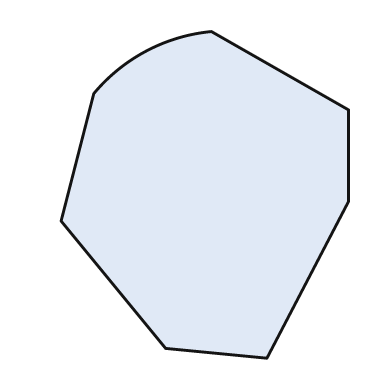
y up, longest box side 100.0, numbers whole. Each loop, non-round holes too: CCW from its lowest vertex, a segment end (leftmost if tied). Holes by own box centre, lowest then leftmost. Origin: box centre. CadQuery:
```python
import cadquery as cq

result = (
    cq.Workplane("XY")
    .moveTo(19.0, -50.0)
    .lineTo(44.0, -2.0)
    .lineTo(44.0, 26.0)
    .lineTo(2.0, 50.0)
    .threePointArc((-18.0, 44.0), (-34.0, 31.0))
    .lineTo(-44.0, -8.0)
    .lineTo(-12.0, -47.0)
    .close()
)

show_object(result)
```